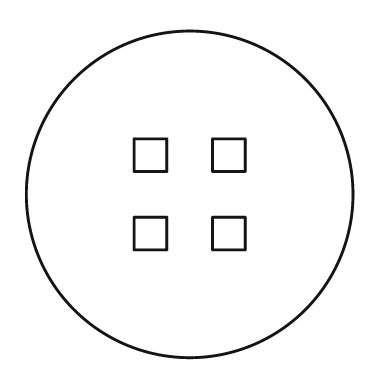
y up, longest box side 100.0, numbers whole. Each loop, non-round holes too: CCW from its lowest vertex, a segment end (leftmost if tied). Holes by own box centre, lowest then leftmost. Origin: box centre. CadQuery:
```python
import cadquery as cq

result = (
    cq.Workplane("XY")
    .moveTo(0.0, 0.0)
    .circle(50.0)
    .moveTo(-17.0, -17.0)
    .lineTo(-7.0, -17.0)
    .lineTo(-7.0, -7.0)
    .lineTo(-17.0, -7.0)
    .close()
    .moveTo(7.0, -17.0)
    .lineTo(17.0, -17.0)
    .lineTo(17.0, -7.0)
    .lineTo(7.0, -7.0)
    .close()
    .moveTo(-17.0, 7.0)
    .lineTo(-7.0, 7.0)
    .lineTo(-7.0, 17.0)
    .lineTo(-17.0, 17.0)
    .close()
    .moveTo(7.0, 7.0)
    .lineTo(17.0, 7.0)
    .lineTo(17.0, 17.0)
    .lineTo(7.0, 17.0)
    .close()
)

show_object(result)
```